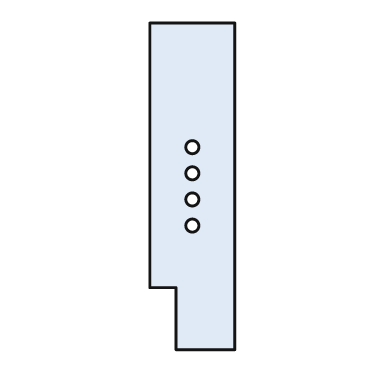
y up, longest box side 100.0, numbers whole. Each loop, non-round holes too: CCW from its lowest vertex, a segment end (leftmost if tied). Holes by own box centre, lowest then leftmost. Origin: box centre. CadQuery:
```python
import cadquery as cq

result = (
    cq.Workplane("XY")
    .moveTo(-5.0, -50.0)
    .lineTo(13.0, -50.0)
    .lineTo(13.0, 50.0)
    .lineTo(-13.0, 50.0)
    .lineTo(-13.0, -31.0)
    .lineTo(-5.0, -31.0)
    .close()
    .moveTo(0.0, -12.0)
    .circle(2.0)
    .moveTo(0.0, -4.0)
    .circle(2.0)
    .moveTo(0.0, 4.0)
    .circle(2.0)
    .moveTo(0.0, 12.0)
    .circle(2.0)
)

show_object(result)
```